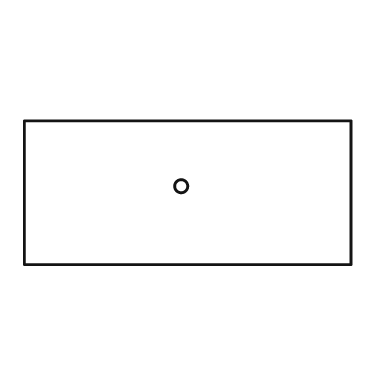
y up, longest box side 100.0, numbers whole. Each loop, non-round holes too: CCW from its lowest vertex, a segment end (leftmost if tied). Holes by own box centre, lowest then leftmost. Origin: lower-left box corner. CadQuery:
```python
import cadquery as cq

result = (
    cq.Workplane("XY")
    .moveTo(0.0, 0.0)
    .lineTo(100.0, 0.0)
    .lineTo(100.0, 44.0)
    .lineTo(0.0, 44.0)
    .close()
    .moveTo(48.0, 24.0)
    .circle(2.0)
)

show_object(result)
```